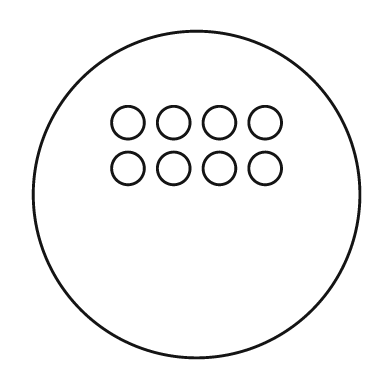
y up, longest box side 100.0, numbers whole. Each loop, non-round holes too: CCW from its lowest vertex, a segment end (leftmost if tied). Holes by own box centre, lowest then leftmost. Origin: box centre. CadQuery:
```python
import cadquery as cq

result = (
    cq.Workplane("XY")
    .moveTo(0.0, 0.0)
    .circle(50.0)
    .moveTo(-21.0, 8.0)
    .circle(5.0)
    .moveTo(-7.0, 8.0)
    .circle(5.0)
    .moveTo(7.0, 8.0)
    .circle(5.0)
    .moveTo(21.0, 8.0)
    .circle(5.0)
    .moveTo(-21.0, 22.0)
    .circle(5.0)
    .moveTo(-7.0, 22.0)
    .circle(5.0)
    .moveTo(7.0, 22.0)
    .circle(5.0)
    .moveTo(21.0, 22.0)
    .circle(5.0)
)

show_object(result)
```